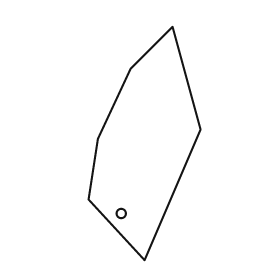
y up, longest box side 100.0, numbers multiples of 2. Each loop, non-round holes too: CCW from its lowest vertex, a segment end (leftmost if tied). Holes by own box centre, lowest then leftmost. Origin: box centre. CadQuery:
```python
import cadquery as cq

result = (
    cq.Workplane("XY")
    .moveTo(0.0, -50.0)
    .lineTo(24.0, 6.0)
    .lineTo(12.0, 50.0)
    .lineTo(-6.0, 32.0)
    .lineTo(-20.0, 2.0)
    .lineTo(-24.0, -24.0)
    .close()
    .moveTo(-10.0, -30.0)
    .circle(2.0)
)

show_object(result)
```